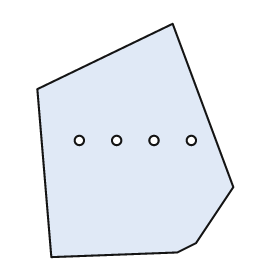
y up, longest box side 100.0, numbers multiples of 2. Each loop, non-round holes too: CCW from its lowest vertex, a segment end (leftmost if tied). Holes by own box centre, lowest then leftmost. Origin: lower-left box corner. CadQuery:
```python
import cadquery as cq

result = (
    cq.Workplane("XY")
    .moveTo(6.0, 0.0)
    .lineTo(60.0, 2.0)
    .lineTo(68.0, 6.0)
    .lineTo(84.0, 30.0)
    .lineTo(58.0, 100.0)
    .lineTo(0.0, 72.0)
    .close()
    .moveTo(18.0, 50.0)
    .circle(2.0)
    .moveTo(34.0, 50.0)
    .circle(2.0)
    .moveTo(50.0, 50.0)
    .circle(2.0)
    .moveTo(66.0, 50.0)
    .circle(2.0)
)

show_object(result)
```